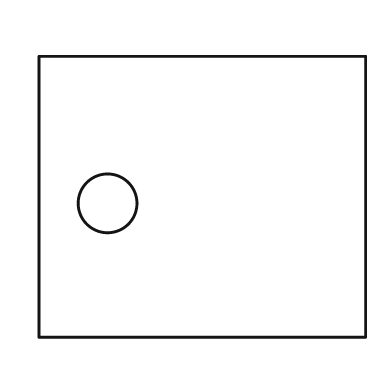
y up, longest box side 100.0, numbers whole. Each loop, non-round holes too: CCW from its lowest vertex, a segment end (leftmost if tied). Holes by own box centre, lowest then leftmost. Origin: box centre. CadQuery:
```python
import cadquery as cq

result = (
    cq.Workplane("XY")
    .moveTo(-50.0, -43.0)
    .lineTo(50.0, -43.0)
    .lineTo(50.0, 43.0)
    .lineTo(-50.0, 43.0)
    .close()
    .moveTo(-29.0, -2.0)
    .circle(9.0)
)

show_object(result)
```